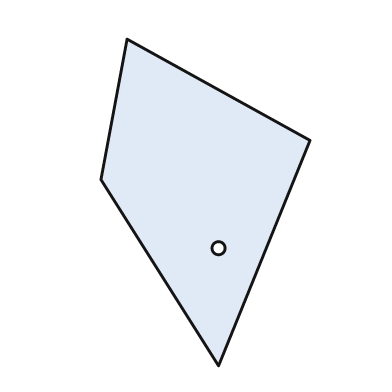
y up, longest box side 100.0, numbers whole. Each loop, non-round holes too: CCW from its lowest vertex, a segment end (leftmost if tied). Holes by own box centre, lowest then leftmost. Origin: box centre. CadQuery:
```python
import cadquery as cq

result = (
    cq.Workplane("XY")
    .moveTo(4.0, -50.0)
    .lineTo(32.0, 19.0)
    .lineTo(-24.0, 50.0)
    .lineTo(-32.0, 7.0)
    .close()
    .moveTo(4.0, -14.0)
    .circle(2.0)
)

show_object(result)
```